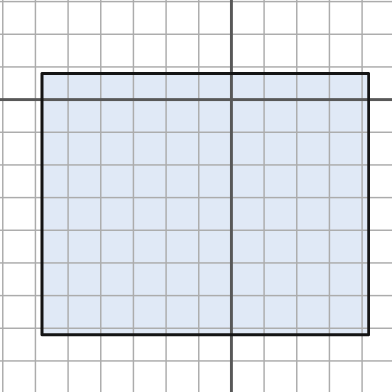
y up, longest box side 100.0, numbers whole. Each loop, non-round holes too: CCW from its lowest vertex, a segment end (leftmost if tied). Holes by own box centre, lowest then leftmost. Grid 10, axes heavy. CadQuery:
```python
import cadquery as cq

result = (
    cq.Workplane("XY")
    .moveTo(-58.0, -72.0)
    .lineTo(42.0, -72.0)
    .lineTo(42.0, 8.0)
    .lineTo(-58.0, 8.0)
    .close()
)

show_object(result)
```